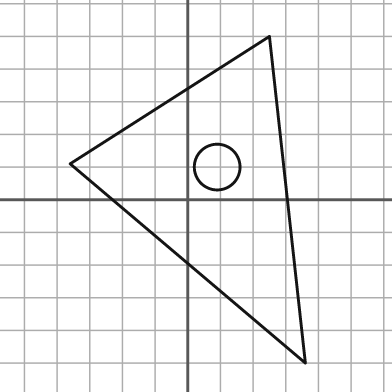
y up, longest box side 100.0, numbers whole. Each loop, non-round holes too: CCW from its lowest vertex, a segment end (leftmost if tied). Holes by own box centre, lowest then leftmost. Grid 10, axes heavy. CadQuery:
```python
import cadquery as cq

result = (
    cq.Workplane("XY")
    .moveTo(36.0, -50.0)
    .lineTo(25.0, 50.0)
    .lineTo(-36.0, 11.0)
    .close()
    .moveTo(9.0, 10.0)
    .circle(7.0)
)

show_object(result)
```